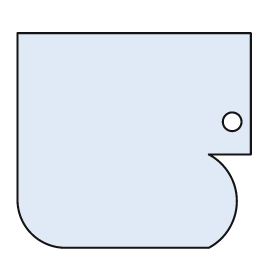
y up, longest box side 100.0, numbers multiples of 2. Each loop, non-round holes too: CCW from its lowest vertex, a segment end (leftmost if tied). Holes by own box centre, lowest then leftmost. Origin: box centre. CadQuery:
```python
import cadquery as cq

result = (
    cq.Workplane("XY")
    .moveTo(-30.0, -46.0)
    .lineTo(32.0, -46.0)
    .threePointArc((44.0, -26.0), (32.0, -6.0))
    .lineTo(50.0, -6.0)
    .lineTo(50.0, 46.0)
    .lineTo(-50.0, 46.0)
    .lineTo(-50.0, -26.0)
    .threePointArc((-44.0, -40.0), (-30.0, -46.0))
    .close()
    .moveTo(42.0, 8.0)
    .circle(4.0)
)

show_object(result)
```